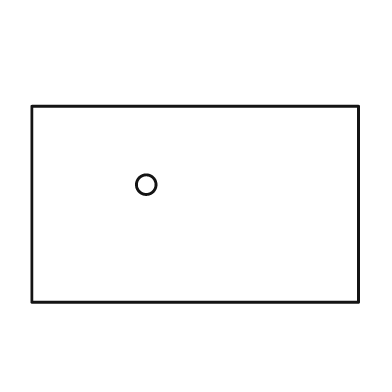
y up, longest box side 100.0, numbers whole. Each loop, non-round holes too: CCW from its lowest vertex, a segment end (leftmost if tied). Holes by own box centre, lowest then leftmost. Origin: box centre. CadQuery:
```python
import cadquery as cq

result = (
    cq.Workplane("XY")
    .moveTo(-50.0, -30.0)
    .lineTo(50.0, -30.0)
    .lineTo(50.0, 30.0)
    .lineTo(-50.0, 30.0)
    .close()
    .moveTo(-15.0, 6.0)
    .circle(3.0)
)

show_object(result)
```